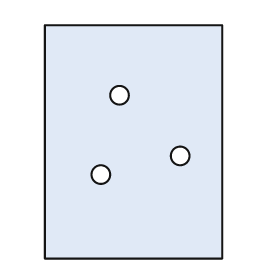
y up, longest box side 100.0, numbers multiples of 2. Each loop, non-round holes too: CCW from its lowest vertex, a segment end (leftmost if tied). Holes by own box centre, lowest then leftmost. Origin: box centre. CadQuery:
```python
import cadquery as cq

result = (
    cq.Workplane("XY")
    .moveTo(-38.0, -50.0)
    .lineTo(38.0, -50.0)
    .lineTo(38.0, 50.0)
    .lineTo(-38.0, 50.0)
    .close()
    .moveTo(-14.0, -14.0)
    .circle(4.0)
    .moveTo(20.0, -6.0)
    .circle(4.0)
    .moveTo(-6.0, 20.0)
    .circle(4.0)
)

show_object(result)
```